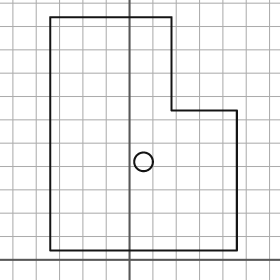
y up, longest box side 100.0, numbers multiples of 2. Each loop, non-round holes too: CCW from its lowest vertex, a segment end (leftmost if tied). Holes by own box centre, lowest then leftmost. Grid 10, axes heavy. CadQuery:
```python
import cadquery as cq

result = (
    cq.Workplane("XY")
    .moveTo(-34.0, 4.0)
    .lineTo(46.0, 4.0)
    .lineTo(46.0, 64.0)
    .lineTo(18.0, 64.0)
    .lineTo(18.0, 104.0)
    .lineTo(-34.0, 104.0)
    .close()
    .moveTo(6.0, 42.0)
    .circle(4.0)
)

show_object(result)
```